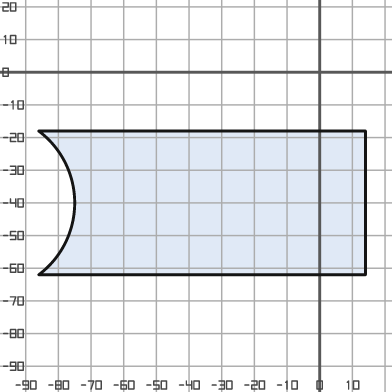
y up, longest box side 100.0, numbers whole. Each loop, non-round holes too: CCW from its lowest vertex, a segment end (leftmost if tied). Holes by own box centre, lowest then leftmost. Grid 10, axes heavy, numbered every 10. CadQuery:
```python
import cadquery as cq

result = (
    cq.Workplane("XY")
    .moveTo(-86.0, -62.0)
    .lineTo(14.0, -62.0)
    .lineTo(14.0, -18.0)
    .lineTo(-86.0, -18.0)
    .threePointArc((-75.0, -40.0), (-86.0, -62.0))
    .close()
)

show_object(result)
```